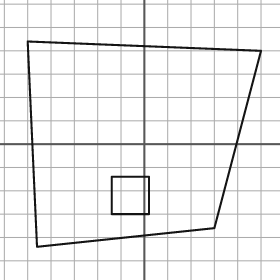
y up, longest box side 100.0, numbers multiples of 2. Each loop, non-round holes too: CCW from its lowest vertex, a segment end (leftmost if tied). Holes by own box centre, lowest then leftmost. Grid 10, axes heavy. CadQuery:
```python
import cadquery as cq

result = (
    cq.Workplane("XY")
    .moveTo(-46.0, -44.0)
    .lineTo(30.0, -36.0)
    .lineTo(50.0, 40.0)
    .lineTo(-50.0, 44.0)
    .close()
    .moveTo(-14.0, -30.0)
    .lineTo(2.0, -30.0)
    .lineTo(2.0, -14.0)
    .lineTo(-14.0, -14.0)
    .close()
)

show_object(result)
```